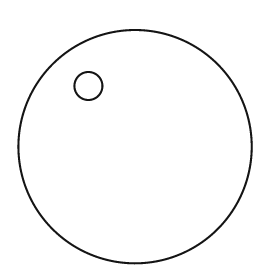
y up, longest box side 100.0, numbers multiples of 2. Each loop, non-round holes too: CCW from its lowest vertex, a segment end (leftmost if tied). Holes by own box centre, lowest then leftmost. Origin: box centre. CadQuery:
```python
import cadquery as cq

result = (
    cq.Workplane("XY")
    .moveTo(0.0, 0.0)
    .circle(50.0)
    .moveTo(-20.0, 26.0)
    .circle(6.0)
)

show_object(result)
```